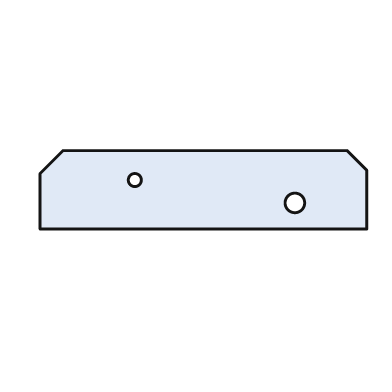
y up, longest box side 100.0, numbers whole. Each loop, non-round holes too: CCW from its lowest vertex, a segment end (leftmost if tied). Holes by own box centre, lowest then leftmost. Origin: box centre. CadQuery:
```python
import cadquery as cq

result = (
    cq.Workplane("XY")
    .moveTo(-50.0, -12.0)
    .lineTo(50.0, -12.0)
    .lineTo(50.0, 6.0)
    .lineTo(44.0, 12.0)
    .lineTo(-43.0, 12.0)
    .lineTo(-50.0, 5.0)
    .close()
    .moveTo(28.0, -4.0)
    .circle(3.0)
    .moveTo(-21.0, 3.0)
    .circle(2.0)
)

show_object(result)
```